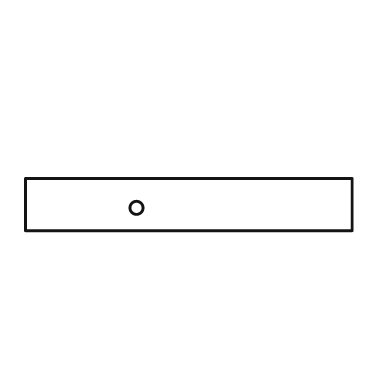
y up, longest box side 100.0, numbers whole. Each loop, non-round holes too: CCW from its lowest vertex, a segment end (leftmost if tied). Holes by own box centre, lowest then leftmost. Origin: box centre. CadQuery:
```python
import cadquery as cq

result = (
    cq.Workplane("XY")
    .moveTo(-50.0, -8.0)
    .lineTo(50.0, -8.0)
    .lineTo(50.0, 8.0)
    .lineTo(-50.0, 8.0)
    .close()
    .moveTo(-16.0, -1.0)
    .circle(2.0)
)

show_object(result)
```